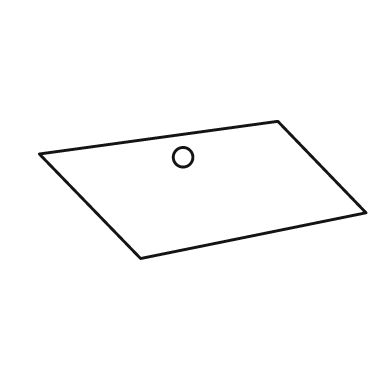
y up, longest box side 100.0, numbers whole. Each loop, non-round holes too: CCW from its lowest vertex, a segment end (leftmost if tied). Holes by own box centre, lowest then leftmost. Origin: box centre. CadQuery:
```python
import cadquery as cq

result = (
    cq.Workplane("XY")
    .moveTo(-19.0, -21.0)
    .lineTo(50.0, -7.0)
    .lineTo(23.0, 21.0)
    .lineTo(-50.0, 11.0)
    .close()
    .moveTo(-6.0, 10.0)
    .circle(3.0)
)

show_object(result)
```